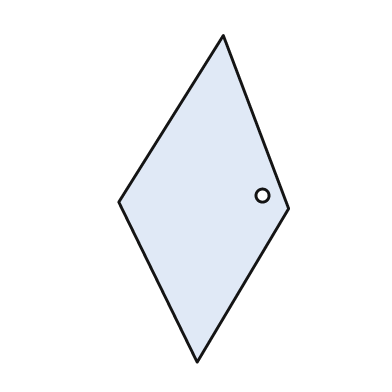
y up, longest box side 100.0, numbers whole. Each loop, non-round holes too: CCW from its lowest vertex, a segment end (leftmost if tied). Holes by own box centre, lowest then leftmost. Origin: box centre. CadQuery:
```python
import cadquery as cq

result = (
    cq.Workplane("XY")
    .moveTo(-2.0, -50.0)
    .lineTo(26.0, -3.0)
    .lineTo(6.0, 50.0)
    .lineTo(-26.0, -1.0)
    .close()
    .moveTo(18.0, 1.0)
    .circle(2.0)
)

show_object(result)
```